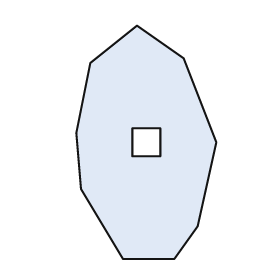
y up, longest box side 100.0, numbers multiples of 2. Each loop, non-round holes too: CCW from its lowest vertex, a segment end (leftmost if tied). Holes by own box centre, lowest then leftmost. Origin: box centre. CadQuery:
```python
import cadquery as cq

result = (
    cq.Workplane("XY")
    .moveTo(-10.0, -50.0)
    .lineTo(12.0, -50.0)
    .lineTo(22.0, -36.0)
    .lineTo(30.0, 0.0)
    .lineTo(16.0, 36.0)
    .lineTo(-4.0, 50.0)
    .lineTo(-24.0, 34.0)
    .lineTo(-30.0, 4.0)
    .lineTo(-28.0, -20.0)
    .close()
    .moveTo(-6.0, -6.0)
    .lineTo(6.0, -6.0)
    .lineTo(6.0, 6.0)
    .lineTo(-6.0, 6.0)
    .close()
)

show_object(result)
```